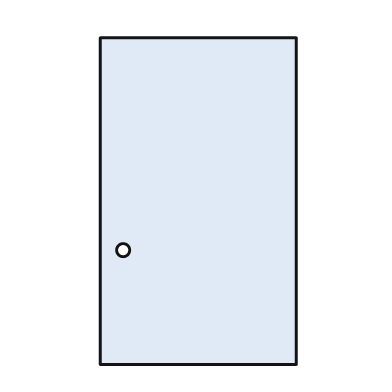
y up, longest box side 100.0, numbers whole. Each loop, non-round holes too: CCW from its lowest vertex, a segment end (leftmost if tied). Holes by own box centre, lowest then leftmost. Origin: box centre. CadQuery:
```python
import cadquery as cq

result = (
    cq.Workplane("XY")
    .moveTo(-30.0, -50.0)
    .lineTo(30.0, -50.0)
    .lineTo(30.0, 50.0)
    .lineTo(-30.0, 50.0)
    .close()
    .moveTo(-23.0, -15.0)
    .circle(2.0)
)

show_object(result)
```